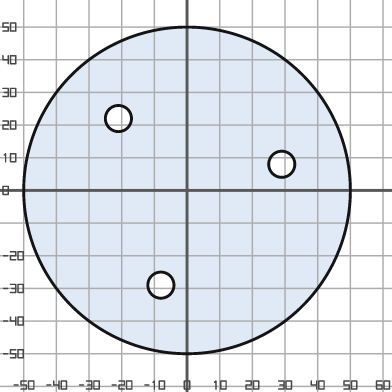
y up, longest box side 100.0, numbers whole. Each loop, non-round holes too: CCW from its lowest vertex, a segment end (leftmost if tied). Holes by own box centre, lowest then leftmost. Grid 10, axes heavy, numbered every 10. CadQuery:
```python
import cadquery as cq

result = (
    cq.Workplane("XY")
    .moveTo(0.0, 0.0)
    .circle(50.0)
    .moveTo(-8.0, -29.0)
    .circle(4.0)
    .moveTo(29.0, 8.0)
    .circle(4.0)
    .moveTo(-21.0, 22.0)
    .circle(4.0)
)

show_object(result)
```